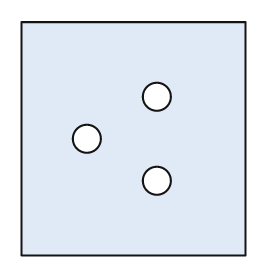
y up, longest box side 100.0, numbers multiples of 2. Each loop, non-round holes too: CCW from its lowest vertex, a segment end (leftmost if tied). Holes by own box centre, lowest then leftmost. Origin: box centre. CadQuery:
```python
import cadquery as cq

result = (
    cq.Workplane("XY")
    .moveTo(-48.0, -50.0)
    .lineTo(48.0, -50.0)
    .lineTo(48.0, 50.0)
    .lineTo(-48.0, 50.0)
    .close()
    .moveTo(10.0, -18.0)
    .circle(6.0)
    .moveTo(-20.0, 0.0)
    .circle(6.0)
    .moveTo(10.0, 18.0)
    .circle(6.0)
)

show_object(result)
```